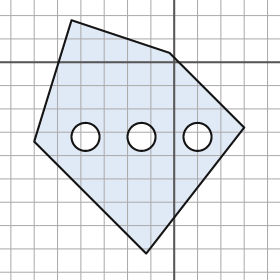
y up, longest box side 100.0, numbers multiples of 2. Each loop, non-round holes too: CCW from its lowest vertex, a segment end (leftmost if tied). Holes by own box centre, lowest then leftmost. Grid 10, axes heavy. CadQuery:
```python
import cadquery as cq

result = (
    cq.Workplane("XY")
    .moveTo(-12.0, -82.0)
    .lineTo(30.0, -28.0)
    .lineTo(-2.0, 4.0)
    .lineTo(-44.0, 18.0)
    .lineTo(-60.0, -34.0)
    .close()
    .moveTo(-38.0, -32.0)
    .circle(6.0)
    .moveTo(-14.0, -32.0)
    .circle(6.0)
    .moveTo(10.0, -32.0)
    .circle(6.0)
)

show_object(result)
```